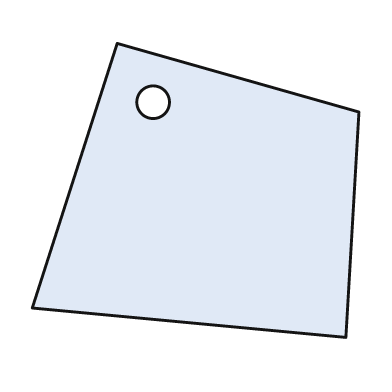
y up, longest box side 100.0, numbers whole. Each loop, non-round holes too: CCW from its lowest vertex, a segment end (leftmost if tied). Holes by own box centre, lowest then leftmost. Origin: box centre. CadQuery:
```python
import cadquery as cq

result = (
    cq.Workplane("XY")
    .moveTo(46.0, -45.0)
    .lineTo(50.0, 24.0)
    .lineTo(-24.0, 45.0)
    .lineTo(-50.0, -36.0)
    .close()
    .moveTo(-13.0, 27.0)
    .circle(5.0)
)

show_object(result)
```